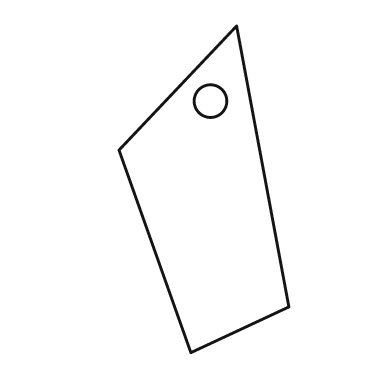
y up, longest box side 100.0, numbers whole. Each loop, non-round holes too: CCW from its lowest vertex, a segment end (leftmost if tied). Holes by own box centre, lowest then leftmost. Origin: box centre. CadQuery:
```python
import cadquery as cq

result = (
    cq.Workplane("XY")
    .moveTo(-4.0, -50.0)
    .lineTo(26.0, -36.0)
    .lineTo(10.0, 50.0)
    .lineTo(-26.0, 12.0)
    .close()
    .moveTo(2.0, 27.0)
    .circle(5.0)
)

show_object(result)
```